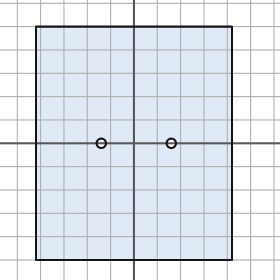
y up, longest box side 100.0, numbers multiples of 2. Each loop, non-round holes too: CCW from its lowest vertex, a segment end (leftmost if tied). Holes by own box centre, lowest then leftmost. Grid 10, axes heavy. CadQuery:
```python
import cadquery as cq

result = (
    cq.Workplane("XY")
    .moveTo(-42.0, -50.0)
    .lineTo(42.0, -50.0)
    .lineTo(42.0, 50.0)
    .lineTo(-42.0, 50.0)
    .close()
    .moveTo(-14.0, 0.0)
    .circle(2.0)
    .moveTo(16.0, 0.0)
    .circle(2.0)
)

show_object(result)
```